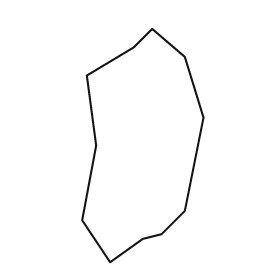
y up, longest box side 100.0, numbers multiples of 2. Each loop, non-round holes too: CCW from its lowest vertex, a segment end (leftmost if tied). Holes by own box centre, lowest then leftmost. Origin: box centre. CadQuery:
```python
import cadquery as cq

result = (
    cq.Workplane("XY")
    .moveTo(-14.0, -50.0)
    .lineTo(0.0, -40.0)
    .lineTo(8.0, -38.0)
    .lineTo(18.0, -28.0)
    .lineTo(26.0, 12.0)
    .lineTo(18.0, 38.0)
    .lineTo(4.0, 50.0)
    .lineTo(-4.0, 42.0)
    .lineTo(-24.0, 30.0)
    .lineTo(-20.0, 0.0)
    .lineTo(-26.0, -32.0)
    .close()
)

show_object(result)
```